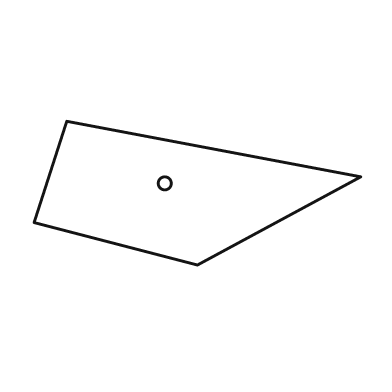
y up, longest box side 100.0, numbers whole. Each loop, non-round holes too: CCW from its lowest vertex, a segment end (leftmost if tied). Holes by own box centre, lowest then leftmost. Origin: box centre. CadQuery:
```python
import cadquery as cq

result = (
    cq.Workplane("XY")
    .moveTo(0.0, -22.0)
    .lineTo(50.0, 5.0)
    .lineTo(-40.0, 22.0)
    .lineTo(-50.0, -9.0)
    .close()
    .moveTo(-10.0, 3.0)
    .circle(2.0)
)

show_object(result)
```